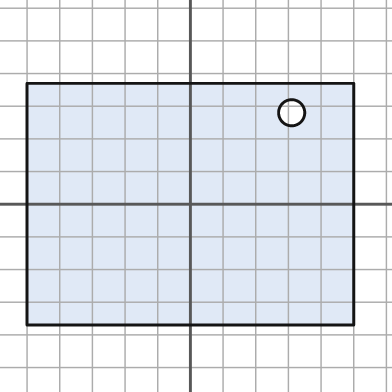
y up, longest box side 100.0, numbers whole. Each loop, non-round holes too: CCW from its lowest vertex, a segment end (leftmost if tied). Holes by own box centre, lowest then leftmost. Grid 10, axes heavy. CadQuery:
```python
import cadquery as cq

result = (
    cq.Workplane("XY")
    .moveTo(-50.0, -37.0)
    .lineTo(50.0, -37.0)
    .lineTo(50.0, 37.0)
    .lineTo(-50.0, 37.0)
    .close()
    .moveTo(31.0, 28.0)
    .circle(4.0)
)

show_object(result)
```